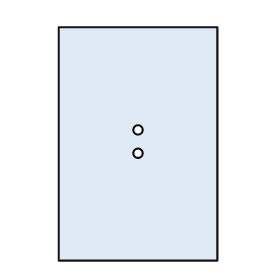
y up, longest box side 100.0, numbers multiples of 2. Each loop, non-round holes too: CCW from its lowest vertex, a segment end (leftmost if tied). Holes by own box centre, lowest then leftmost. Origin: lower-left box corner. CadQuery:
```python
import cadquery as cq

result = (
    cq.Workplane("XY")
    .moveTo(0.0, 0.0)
    .lineTo(68.0, 0.0)
    .lineTo(68.0, 100.0)
    .lineTo(0.0, 100.0)
    .close()
    .moveTo(34.0, 46.0)
    .circle(2.0)
    .moveTo(34.0, 56.0)
    .circle(2.0)
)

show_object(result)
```